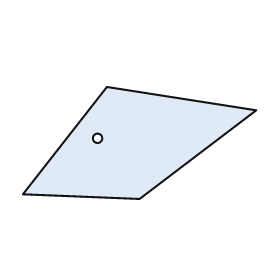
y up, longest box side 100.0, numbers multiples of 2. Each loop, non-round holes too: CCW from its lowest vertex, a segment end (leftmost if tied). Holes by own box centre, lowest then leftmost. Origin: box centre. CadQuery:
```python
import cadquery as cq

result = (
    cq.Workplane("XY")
    .moveTo(0.0, -24.0)
    .lineTo(50.0, 14.0)
    .lineTo(-14.0, 24.0)
    .lineTo(-50.0, -22.0)
    .close()
    .moveTo(-18.0, 2.0)
    .circle(2.0)
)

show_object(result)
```